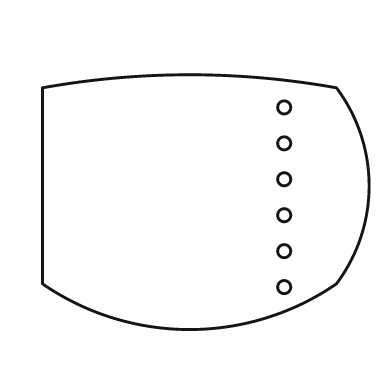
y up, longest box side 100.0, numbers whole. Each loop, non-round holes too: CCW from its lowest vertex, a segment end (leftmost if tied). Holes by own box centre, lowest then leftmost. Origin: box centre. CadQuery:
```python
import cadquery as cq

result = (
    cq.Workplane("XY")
    .moveTo(-50.0, -25.0)
    .threePointArc((-5.0, -39.0), (40.0, -25.0))
    .threePointArc((50.0, 5.0), (40.0, 35.0))
    .threePointArc((-5.0, 39.0), (-50.0, 35.0))
    .close()
    .moveTo(24.0, -26.0)
    .circle(2.0)
    .moveTo(24.0, -15.0)
    .circle(2.0)
    .moveTo(24.0, -4.0)
    .circle(2.0)
    .moveTo(24.0, 7.0)
    .circle(2.0)
    .moveTo(24.0, 18.0)
    .circle(2.0)
    .moveTo(24.0, 29.0)
    .circle(2.0)
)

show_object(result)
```